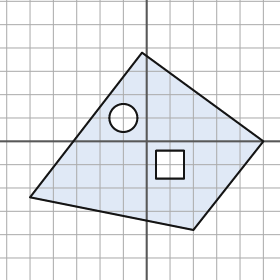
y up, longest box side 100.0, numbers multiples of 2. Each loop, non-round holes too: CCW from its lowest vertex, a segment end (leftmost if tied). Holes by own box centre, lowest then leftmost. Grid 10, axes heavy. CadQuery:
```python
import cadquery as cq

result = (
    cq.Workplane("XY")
    .moveTo(20.0, -38.0)
    .lineTo(50.0, 0.0)
    .lineTo(-2.0, 38.0)
    .lineTo(-50.0, -24.0)
    .close()
    .moveTo(4.0, -16.0)
    .lineTo(16.0, -16.0)
    .lineTo(16.0, -4.0)
    .lineTo(4.0, -4.0)
    .close()
    .moveTo(-10.0, 10.0)
    .circle(6.0)
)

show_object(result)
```